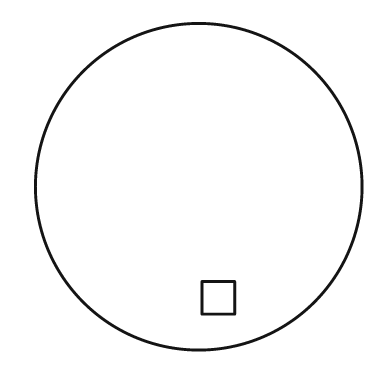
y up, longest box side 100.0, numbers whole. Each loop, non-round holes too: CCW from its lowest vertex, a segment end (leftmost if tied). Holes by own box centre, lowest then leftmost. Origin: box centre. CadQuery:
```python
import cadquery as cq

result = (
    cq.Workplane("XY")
    .moveTo(0.0, 0.0)
    .circle(50.0)
    .moveTo(1.0, -39.0)
    .lineTo(11.0, -39.0)
    .lineTo(11.0, -29.0)
    .lineTo(1.0, -29.0)
    .close()
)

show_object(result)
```